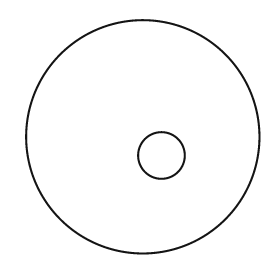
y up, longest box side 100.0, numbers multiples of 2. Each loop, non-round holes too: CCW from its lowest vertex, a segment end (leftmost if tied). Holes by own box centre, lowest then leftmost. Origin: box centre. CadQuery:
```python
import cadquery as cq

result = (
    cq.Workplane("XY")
    .moveTo(0.0, 0.0)
    .circle(50.0)
    .moveTo(8.0, -8.0)
    .circle(10.0)
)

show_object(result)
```